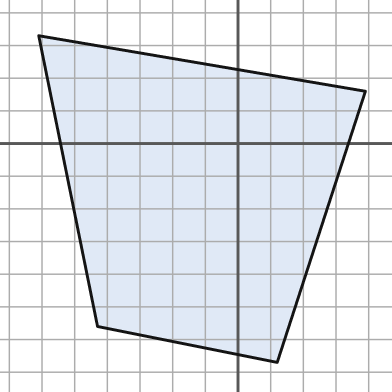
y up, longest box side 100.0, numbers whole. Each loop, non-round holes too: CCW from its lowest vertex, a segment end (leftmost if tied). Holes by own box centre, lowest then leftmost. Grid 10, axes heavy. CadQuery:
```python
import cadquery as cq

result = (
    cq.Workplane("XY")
    .moveTo(12.0, -67.0)
    .lineTo(39.0, 16.0)
    .lineTo(-61.0, 33.0)
    .lineTo(-43.0, -56.0)
    .close()
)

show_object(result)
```